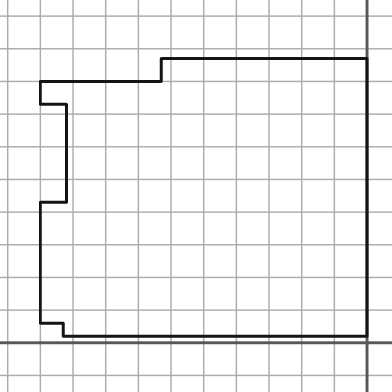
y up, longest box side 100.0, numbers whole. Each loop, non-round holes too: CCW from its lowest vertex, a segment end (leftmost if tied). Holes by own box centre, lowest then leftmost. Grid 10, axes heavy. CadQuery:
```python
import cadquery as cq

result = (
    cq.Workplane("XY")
    .moveTo(-93.0, 2.0)
    .lineTo(0.0, 2.0)
    .lineTo(0.0, 87.0)
    .lineTo(-63.0, 87.0)
    .lineTo(-63.0, 80.0)
    .lineTo(-100.0, 80.0)
    .lineTo(-100.0, 73.0)
    .lineTo(-92.0, 73.0)
    .lineTo(-92.0, 43.0)
    .lineTo(-100.0, 43.0)
    .lineTo(-100.0, 6.0)
    .lineTo(-93.0, 6.0)
    .close()
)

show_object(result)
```